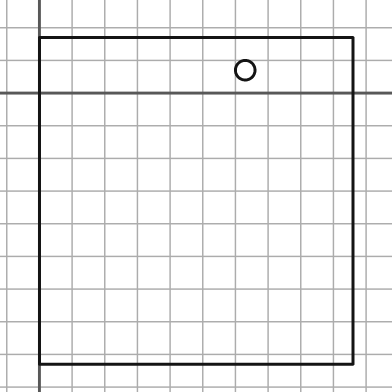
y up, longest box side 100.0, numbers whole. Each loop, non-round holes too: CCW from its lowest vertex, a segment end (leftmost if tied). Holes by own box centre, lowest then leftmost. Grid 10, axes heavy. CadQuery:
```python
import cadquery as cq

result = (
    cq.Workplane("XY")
    .moveTo(0.0, -83.0)
    .lineTo(96.0, -83.0)
    .lineTo(96.0, 17.0)
    .lineTo(0.0, 17.0)
    .close()
    .moveTo(63.0, 7.0)
    .circle(3.0)
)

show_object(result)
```